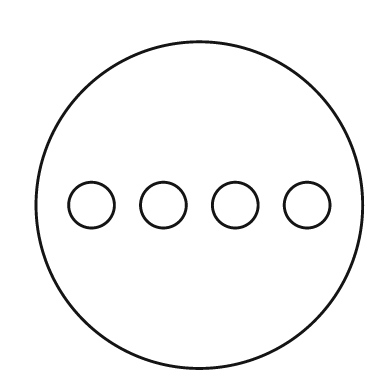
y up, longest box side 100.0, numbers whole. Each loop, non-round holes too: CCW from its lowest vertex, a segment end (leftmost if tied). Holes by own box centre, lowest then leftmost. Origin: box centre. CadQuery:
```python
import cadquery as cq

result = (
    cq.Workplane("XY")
    .moveTo(0.0, 0.0)
    .circle(50.0)
    .moveTo(-33.0, 0.0)
    .circle(7.0)
    .moveTo(-11.0, 0.0)
    .circle(7.0)
    .moveTo(11.0, 0.0)
    .circle(7.0)
    .moveTo(33.0, 0.0)
    .circle(7.0)
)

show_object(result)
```